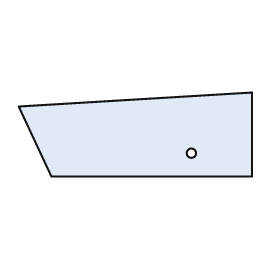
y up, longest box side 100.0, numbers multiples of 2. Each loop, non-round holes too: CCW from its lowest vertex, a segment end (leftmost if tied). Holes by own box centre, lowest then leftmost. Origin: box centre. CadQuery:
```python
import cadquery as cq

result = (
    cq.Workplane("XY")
    .moveTo(-36.0, -18.0)
    .lineTo(50.0, -18.0)
    .lineTo(50.0, 18.0)
    .lineTo(-50.0, 12.0)
    .close()
    .moveTo(24.0, -8.0)
    .circle(2.0)
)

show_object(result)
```